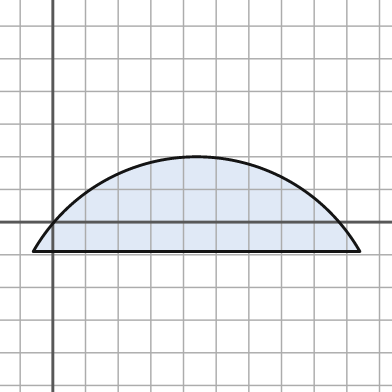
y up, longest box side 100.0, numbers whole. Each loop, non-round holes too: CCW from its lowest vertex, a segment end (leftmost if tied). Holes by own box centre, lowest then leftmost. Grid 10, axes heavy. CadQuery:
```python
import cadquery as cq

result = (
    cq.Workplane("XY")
    .moveTo(-6.0, -9.0)
    .lineTo(94.0, -9.0)
    .threePointArc((44.0, 20.0), (-6.0, -9.0))
    .close()
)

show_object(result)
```